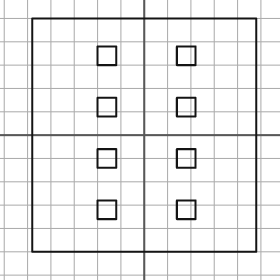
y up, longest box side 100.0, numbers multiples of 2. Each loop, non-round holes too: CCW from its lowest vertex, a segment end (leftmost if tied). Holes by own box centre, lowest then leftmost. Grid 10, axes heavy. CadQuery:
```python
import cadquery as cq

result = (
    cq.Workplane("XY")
    .moveTo(-48.0, -50.0)
    .lineTo(48.0, -50.0)
    .lineTo(48.0, 50.0)
    .lineTo(-48.0, 50.0)
    .close()
    .moveTo(-20.0, -36.0)
    .lineTo(-12.0, -36.0)
    .lineTo(-12.0, -28.0)
    .lineTo(-20.0, -28.0)
    .close()
    .moveTo(14.0, -36.0)
    .lineTo(22.0, -36.0)
    .lineTo(22.0, -28.0)
    .lineTo(14.0, -28.0)
    .close()
    .moveTo(-20.0, -14.0)
    .lineTo(-12.0, -14.0)
    .lineTo(-12.0, -6.0)
    .lineTo(-20.0, -6.0)
    .close()
    .moveTo(14.0, -14.0)
    .lineTo(22.0, -14.0)
    .lineTo(22.0, -6.0)
    .lineTo(14.0, -6.0)
    .close()
    .moveTo(-20.0, 8.0)
    .lineTo(-12.0, 8.0)
    .lineTo(-12.0, 16.0)
    .lineTo(-20.0, 16.0)
    .close()
    .moveTo(14.0, 8.0)
    .lineTo(22.0, 8.0)
    .lineTo(22.0, 16.0)
    .lineTo(14.0, 16.0)
    .close()
    .moveTo(-20.0, 30.0)
    .lineTo(-12.0, 30.0)
    .lineTo(-12.0, 38.0)
    .lineTo(-20.0, 38.0)
    .close()
    .moveTo(14.0, 30.0)
    .lineTo(22.0, 30.0)
    .lineTo(22.0, 38.0)
    .lineTo(14.0, 38.0)
    .close()
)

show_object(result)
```